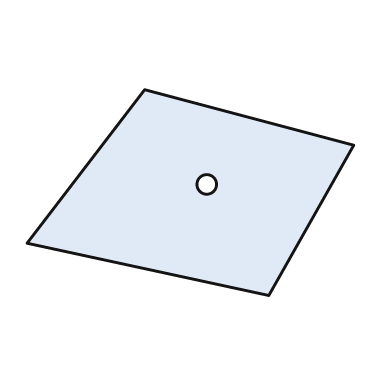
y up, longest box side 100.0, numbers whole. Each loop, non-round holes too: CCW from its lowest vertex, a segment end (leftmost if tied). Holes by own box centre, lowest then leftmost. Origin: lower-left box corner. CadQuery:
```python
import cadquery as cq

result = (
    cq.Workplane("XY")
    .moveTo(74.0, 0.0)
    .lineTo(100.0, 46.0)
    .lineTo(36.0, 63.0)
    .lineTo(0.0, 16.0)
    .close()
    .moveTo(55.0, 34.0)
    .circle(3.0)
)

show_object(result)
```